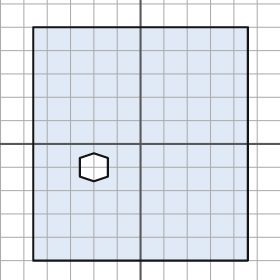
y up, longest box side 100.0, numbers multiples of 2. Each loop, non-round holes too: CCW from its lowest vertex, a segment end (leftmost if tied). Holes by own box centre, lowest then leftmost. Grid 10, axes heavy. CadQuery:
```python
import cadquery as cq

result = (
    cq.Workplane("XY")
    .moveTo(-46.0, -50.0)
    .lineTo(46.0, -50.0)
    .lineTo(46.0, 50.0)
    .lineTo(-46.0, 50.0)
    .close()
    .moveTo(-20.0, -16.0)
    .lineTo(-14.0, -14.0)
    .lineTo(-14.0, -6.0)
    .lineTo(-20.0, -4.0)
    .lineTo(-26.0, -6.0)
    .lineTo(-26.0, -14.0)
    .close()
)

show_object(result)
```